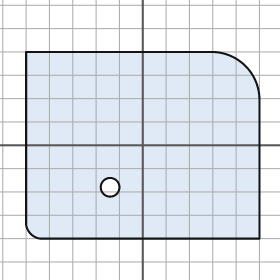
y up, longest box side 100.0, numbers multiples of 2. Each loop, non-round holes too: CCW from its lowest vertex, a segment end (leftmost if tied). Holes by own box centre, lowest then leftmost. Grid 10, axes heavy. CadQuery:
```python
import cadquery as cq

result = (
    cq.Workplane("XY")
    .moveTo(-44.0, -40.0)
    .lineTo(50.0, -40.0)
    .lineTo(50.0, 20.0)
    .threePointArc((44.0, 34.0), (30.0, 40.0))
    .lineTo(-50.0, 40.0)
    .lineTo(-50.0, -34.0)
    .threePointArc((-48.0, -38.0), (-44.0, -40.0))
    .close()
    .moveTo(-14.0, -18.0)
    .circle(4.0)
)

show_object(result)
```